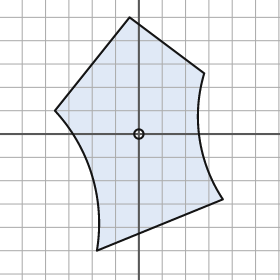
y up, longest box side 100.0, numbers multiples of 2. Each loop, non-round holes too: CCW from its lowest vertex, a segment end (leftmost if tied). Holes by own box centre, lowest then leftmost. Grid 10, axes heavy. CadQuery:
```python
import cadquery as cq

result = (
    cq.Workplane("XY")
    .moveTo(-18.0, -50.0)
    .lineTo(36.0, -28.0)
    .threePointArc((26.0, -2.0), (28.0, 26.0))
    .lineTo(-4.0, 50.0)
    .lineTo(-36.0, 10.0)
    .threePointArc((-20.0, -18.0), (-18.0, -50.0))
    .close()
    .moveTo(0.0, 0.0)
    .circle(2.0)
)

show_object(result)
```